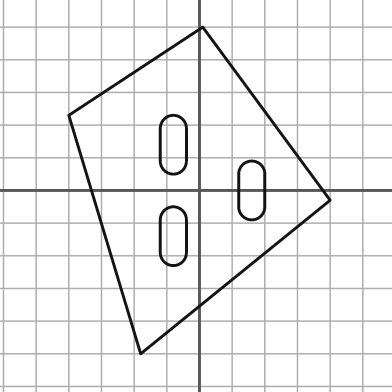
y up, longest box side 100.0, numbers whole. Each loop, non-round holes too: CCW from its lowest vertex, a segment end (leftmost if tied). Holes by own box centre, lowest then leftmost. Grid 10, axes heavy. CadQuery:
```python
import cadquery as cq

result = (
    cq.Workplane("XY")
    .moveTo(-18.0, -50.0)
    .lineTo(40.0, -3.0)
    .lineTo(1.0, 50.0)
    .lineTo(-40.0, 23.0)
    .close()
    .moveTo(-12.0, -19.0)
    .threePointArc((-8.0, -23.0), (-4.0, -19.0))
    .lineTo(-4.0, -9.0)
    .threePointArc((-8.0, -5.0), (-12.0, -9.0))
    .close()
    .moveTo(12.0, -5.0)
    .threePointArc((16.0, -9.0), (20.0, -5.0))
    .lineTo(20.0, 5.0)
    .threePointArc((16.0, 9.0), (12.0, 5.0))
    .close()
    .moveTo(-12.0, 9.0)
    .threePointArc((-8.0, 5.0), (-4.0, 9.0))
    .lineTo(-4.0, 19.0)
    .threePointArc((-8.0, 23.0), (-12.0, 19.0))
    .close()
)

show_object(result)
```